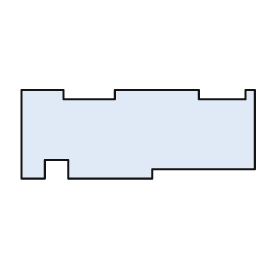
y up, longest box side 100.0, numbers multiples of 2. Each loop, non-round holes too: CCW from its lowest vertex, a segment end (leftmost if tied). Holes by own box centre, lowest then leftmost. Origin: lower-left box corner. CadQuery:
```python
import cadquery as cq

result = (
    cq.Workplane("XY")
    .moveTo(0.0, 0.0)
    .lineTo(10.0, 0.0)
    .lineTo(10.0, 8.0)
    .lineTo(20.0, 8.0)
    .lineTo(20.0, 0.0)
    .lineTo(56.0, 0.0)
    .lineTo(56.0, 4.0)
    .lineTo(100.0, 4.0)
    .lineTo(100.0, 38.0)
    .lineTo(96.0, 38.0)
    .lineTo(96.0, 34.0)
    .lineTo(76.0, 34.0)
    .lineTo(76.0, 38.0)
    .lineTo(40.0, 38.0)
    .lineTo(40.0, 34.0)
    .lineTo(18.0, 34.0)
    .lineTo(18.0, 38.0)
    .lineTo(0.0, 38.0)
    .close()
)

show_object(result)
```